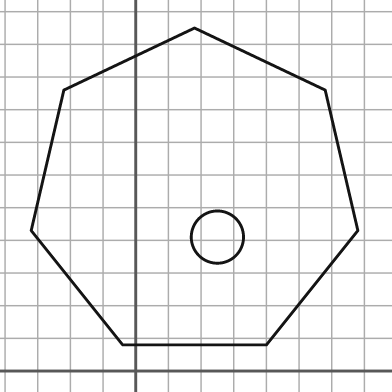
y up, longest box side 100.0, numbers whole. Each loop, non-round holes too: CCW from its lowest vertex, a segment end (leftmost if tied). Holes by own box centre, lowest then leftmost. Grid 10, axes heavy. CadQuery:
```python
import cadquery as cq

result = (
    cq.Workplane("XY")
    .moveTo(-4.0, 8.0)
    .lineTo(40.0, 8.0)
    .lineTo(68.0, 43.0)
    .lineTo(58.0, 86.0)
    .lineTo(18.0, 105.0)
    .lineTo(-22.0, 86.0)
    .lineTo(-32.0, 43.0)
    .close()
    .moveTo(25.0, 41.0)
    .circle(8.0)
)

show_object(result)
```